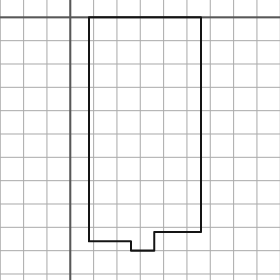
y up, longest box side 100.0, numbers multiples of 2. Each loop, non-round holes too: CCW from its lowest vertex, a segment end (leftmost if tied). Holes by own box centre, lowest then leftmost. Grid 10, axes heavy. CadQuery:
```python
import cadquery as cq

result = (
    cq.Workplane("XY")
    .moveTo(26.0, -100.0)
    .lineTo(36.0, -100.0)
    .lineTo(36.0, -92.0)
    .lineTo(56.0, -92.0)
    .lineTo(56.0, 0.0)
    .lineTo(8.0, 0.0)
    .lineTo(8.0, -96.0)
    .lineTo(26.0, -96.0)
    .close()
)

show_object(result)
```